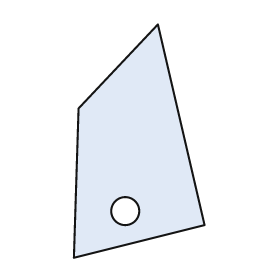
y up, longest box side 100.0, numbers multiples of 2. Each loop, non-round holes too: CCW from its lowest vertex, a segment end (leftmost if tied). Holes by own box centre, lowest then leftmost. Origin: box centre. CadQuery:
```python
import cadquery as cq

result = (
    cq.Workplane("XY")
    .moveTo(-28.0, -50.0)
    .lineTo(28.0, -36.0)
    .lineTo(8.0, 50.0)
    .lineTo(-26.0, 14.0)
    .close()
    .moveTo(-6.0, -30.0)
    .circle(6.0)
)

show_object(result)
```